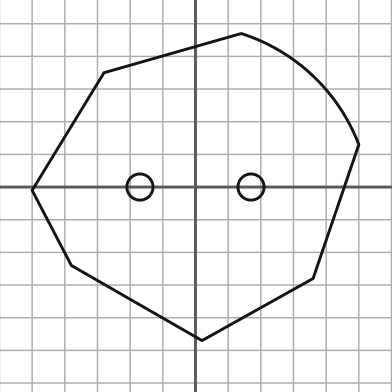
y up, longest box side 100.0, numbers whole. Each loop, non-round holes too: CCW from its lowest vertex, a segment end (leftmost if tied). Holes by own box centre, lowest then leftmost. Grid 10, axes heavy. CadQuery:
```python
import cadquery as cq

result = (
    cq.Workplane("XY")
    .moveTo(2.0, -47.0)
    .lineTo(36.0, -28.0)
    .lineTo(50.0, 13.0)
    .threePointArc((36.0, 34.0), (14.0, 47.0))
    .lineTo(-28.0, 35.0)
    .lineTo(-50.0, -1.0)
    .lineTo(-38.0, -24.0)
    .close()
    .moveTo(-17.0, 0.0)
    .circle(4.0)
    .moveTo(17.0, 0.0)
    .circle(4.0)
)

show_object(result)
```